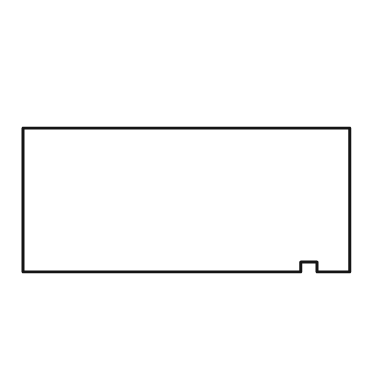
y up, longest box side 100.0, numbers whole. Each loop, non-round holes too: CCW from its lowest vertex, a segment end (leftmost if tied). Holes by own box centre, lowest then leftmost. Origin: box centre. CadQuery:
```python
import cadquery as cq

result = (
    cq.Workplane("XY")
    .moveTo(-50.0, -22.0)
    .lineTo(35.0, -22.0)
    .lineTo(35.0, -19.0)
    .lineTo(40.0, -19.0)
    .lineTo(40.0, -22.0)
    .lineTo(50.0, -22.0)
    .lineTo(50.0, 22.0)
    .lineTo(-50.0, 22.0)
    .close()
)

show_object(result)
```